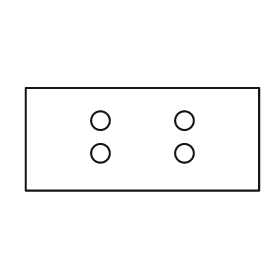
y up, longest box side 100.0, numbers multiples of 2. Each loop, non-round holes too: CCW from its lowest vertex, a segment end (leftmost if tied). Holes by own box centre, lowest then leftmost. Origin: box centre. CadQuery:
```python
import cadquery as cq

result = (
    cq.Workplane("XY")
    .moveTo(-50.0, -22.0)
    .lineTo(50.0, -22.0)
    .lineTo(50.0, 22.0)
    .lineTo(-50.0, 22.0)
    .close()
    .moveTo(-18.0, -6.0)
    .circle(4.0)
    .moveTo(18.0, -6.0)
    .circle(4.0)
    .moveTo(-18.0, 8.0)
    .circle(4.0)
    .moveTo(18.0, 8.0)
    .circle(4.0)
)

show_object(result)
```